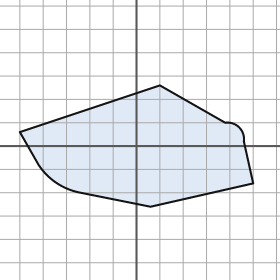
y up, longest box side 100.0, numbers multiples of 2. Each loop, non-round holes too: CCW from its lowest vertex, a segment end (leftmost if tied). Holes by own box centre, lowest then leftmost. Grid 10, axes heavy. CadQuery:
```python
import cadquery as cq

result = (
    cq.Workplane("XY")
    .moveTo(6.0, -26.0)
    .lineTo(50.0, -16.0)
    .lineTo(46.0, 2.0)
    .threePointArc((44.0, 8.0), (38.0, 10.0))
    .lineTo(10.0, 26.0)
    .lineTo(-50.0, 6.0)
    .lineTo(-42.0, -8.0)
    .threePointArc((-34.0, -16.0), (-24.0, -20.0))
    .close()
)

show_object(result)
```